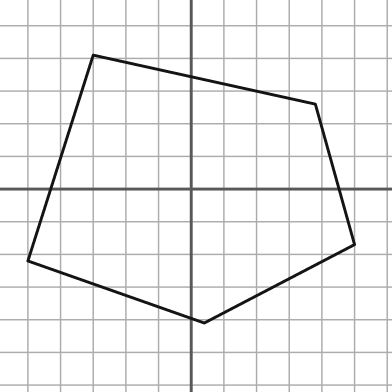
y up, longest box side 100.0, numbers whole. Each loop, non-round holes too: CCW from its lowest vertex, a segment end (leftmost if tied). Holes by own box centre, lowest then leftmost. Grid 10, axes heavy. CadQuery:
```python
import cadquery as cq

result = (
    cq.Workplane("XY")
    .moveTo(4.0, -41.0)
    .lineTo(50.0, -17.0)
    .lineTo(38.0, 26.0)
    .lineTo(-30.0, 41.0)
    .lineTo(-50.0, -22.0)
    .close()
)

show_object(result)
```